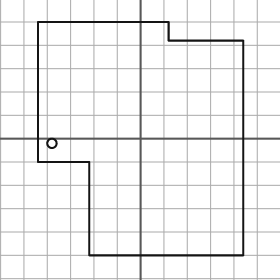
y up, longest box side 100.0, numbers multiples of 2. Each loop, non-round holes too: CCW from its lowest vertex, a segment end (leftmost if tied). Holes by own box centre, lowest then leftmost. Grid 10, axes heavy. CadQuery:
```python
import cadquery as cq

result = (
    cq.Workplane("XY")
    .moveTo(-22.0, -50.0)
    .lineTo(44.0, -50.0)
    .lineTo(44.0, 42.0)
    .lineTo(12.0, 42.0)
    .lineTo(12.0, 50.0)
    .lineTo(-44.0, 50.0)
    .lineTo(-44.0, -10.0)
    .lineTo(-22.0, -10.0)
    .close()
    .moveTo(-38.0, -2.0)
    .circle(2.0)
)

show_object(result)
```